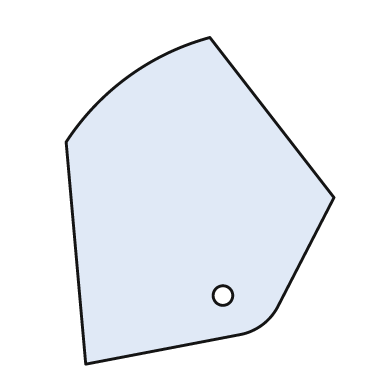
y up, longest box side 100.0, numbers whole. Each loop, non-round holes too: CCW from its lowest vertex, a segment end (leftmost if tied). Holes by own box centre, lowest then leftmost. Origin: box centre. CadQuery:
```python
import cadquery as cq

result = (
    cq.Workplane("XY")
    .moveTo(-35.0, -50.0)
    .lineTo(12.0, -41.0)
    .threePointArc((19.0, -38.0), (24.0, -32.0))
    .lineTo(41.0, 1.0)
    .lineTo(3.0, 50.0)
    .threePointArc((-22.0, 38.0), (-41.0, 18.0))
    .close()
    .moveTo(7.0, -29.0)
    .circle(3.0)
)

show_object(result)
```